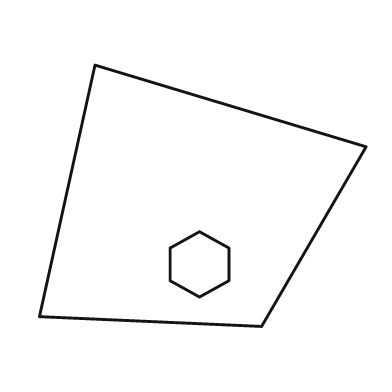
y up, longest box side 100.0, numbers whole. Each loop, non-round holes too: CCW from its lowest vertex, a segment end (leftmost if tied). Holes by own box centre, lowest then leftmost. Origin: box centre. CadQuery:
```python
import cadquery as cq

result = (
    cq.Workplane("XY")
    .moveTo(18.0, -40.0)
    .lineTo(50.0, 15.0)
    .lineTo(-33.0, 40.0)
    .lineTo(-50.0, -37.0)
    .close()
    .moveTo(-1.0, -31.0)
    .lineTo(8.0, -26.0)
    .lineTo(8.0, -16.0)
    .lineTo(-1.0, -11.0)
    .lineTo(-10.0, -16.0)
    .lineTo(-10.0, -26.0)
    .close()
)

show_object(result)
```